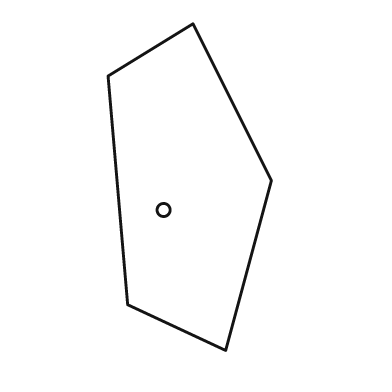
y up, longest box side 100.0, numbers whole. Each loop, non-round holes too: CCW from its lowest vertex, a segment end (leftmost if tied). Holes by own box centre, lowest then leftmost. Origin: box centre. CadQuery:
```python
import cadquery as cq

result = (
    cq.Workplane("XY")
    .moveTo(11.0, -50.0)
    .lineTo(25.0, 2.0)
    .lineTo(1.0, 50.0)
    .lineTo(-25.0, 34.0)
    .lineTo(-19.0, -36.0)
    .close()
    .moveTo(-8.0, -7.0)
    .circle(2.0)
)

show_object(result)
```